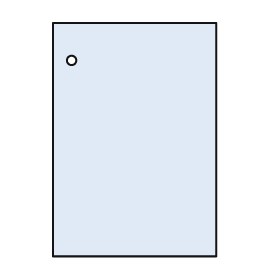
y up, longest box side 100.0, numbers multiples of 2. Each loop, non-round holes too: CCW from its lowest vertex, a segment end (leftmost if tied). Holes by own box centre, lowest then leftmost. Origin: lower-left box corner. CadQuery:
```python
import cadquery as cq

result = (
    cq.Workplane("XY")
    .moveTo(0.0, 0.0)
    .lineTo(70.0, 0.0)
    .lineTo(70.0, 100.0)
    .lineTo(0.0, 100.0)
    .close()
    .moveTo(8.0, 84.0)
    .circle(2.0)
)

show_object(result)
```